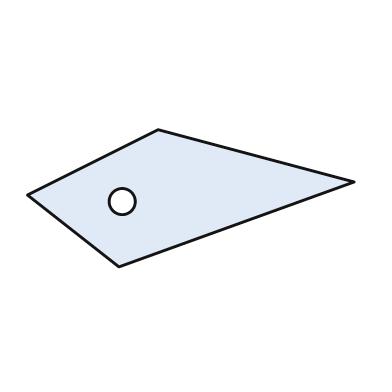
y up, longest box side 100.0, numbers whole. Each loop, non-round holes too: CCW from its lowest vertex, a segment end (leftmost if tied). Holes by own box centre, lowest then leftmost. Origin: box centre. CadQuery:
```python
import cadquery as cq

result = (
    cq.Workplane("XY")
    .moveTo(-22.0, -21.0)
    .lineTo(50.0, 5.0)
    .lineTo(-10.0, 21.0)
    .lineTo(-50.0, 1.0)
    .close()
    .moveTo(-21.0, -1.0)
    .circle(4.0)
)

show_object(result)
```